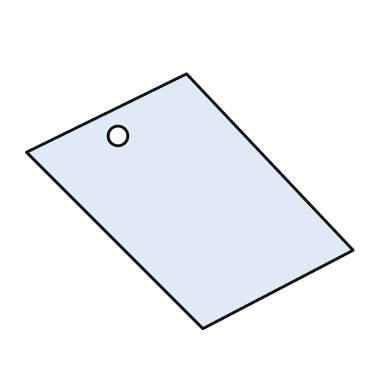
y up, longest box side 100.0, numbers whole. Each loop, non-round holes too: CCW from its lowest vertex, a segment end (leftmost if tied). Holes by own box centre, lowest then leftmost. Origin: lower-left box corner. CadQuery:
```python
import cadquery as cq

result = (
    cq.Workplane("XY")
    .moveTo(54.0, 0.0)
    .lineTo(100.0, 24.0)
    .lineTo(49.0, 78.0)
    .lineTo(0.0, 54.0)
    .close()
    .moveTo(28.0, 59.0)
    .circle(3.0)
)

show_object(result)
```